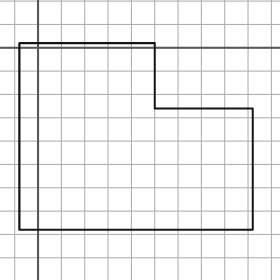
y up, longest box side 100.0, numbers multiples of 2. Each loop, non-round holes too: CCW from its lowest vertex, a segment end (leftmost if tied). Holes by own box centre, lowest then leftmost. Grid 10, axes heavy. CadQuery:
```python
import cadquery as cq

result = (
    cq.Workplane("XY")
    .moveTo(-8.0, -78.0)
    .lineTo(92.0, -78.0)
    .lineTo(92.0, -26.0)
    .lineTo(50.0, -26.0)
    .lineTo(50.0, 2.0)
    .lineTo(-8.0, 2.0)
    .close()
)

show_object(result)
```